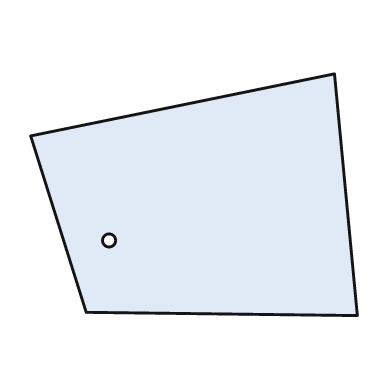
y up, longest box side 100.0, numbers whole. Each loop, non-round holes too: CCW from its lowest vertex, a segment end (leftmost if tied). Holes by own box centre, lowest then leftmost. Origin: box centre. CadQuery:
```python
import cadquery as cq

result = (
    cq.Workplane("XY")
    .moveTo(50.0, -37.0)
    .lineTo(43.0, 37.0)
    .lineTo(-50.0, 18.0)
    .lineTo(-33.0, -36.0)
    .close()
    .moveTo(-26.0, -14.0)
    .circle(2.0)
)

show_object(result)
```